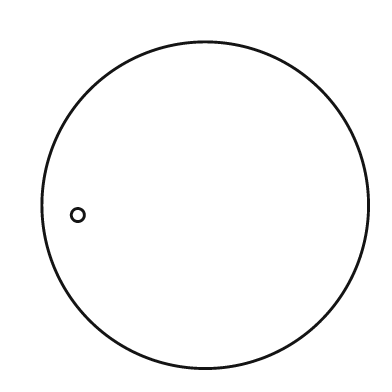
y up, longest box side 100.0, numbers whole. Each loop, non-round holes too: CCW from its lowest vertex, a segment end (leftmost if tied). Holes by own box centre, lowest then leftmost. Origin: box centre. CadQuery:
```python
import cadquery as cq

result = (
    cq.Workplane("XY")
    .moveTo(0.0, 0.0)
    .circle(50.0)
    .moveTo(-39.0, -3.0)
    .circle(2.0)
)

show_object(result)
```